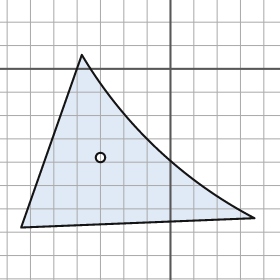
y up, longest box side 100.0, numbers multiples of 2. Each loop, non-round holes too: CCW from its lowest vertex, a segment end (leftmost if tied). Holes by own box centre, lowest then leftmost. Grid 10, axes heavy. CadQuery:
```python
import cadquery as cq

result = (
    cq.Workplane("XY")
    .moveTo(-64.0, -68.0)
    .lineTo(36.0, -64.0)
    .threePointArc((-6.0, -34.0), (-38.0, 6.0))
    .close()
    .moveTo(-30.0, -38.0)
    .circle(2.0)
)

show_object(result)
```